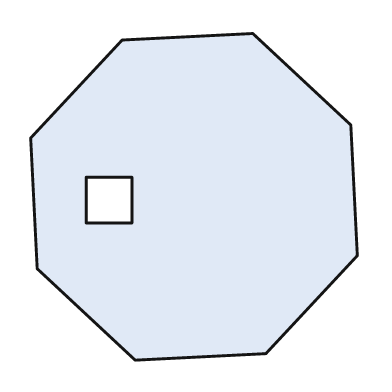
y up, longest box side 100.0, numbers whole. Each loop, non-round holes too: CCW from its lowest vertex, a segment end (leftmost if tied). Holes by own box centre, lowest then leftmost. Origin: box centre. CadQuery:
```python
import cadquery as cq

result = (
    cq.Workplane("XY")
    .moveTo(-18.0, -50.0)
    .lineTo(22.0, -48.0)
    .lineTo(50.0, -18.0)
    .lineTo(48.0, 22.0)
    .lineTo(18.0, 50.0)
    .lineTo(-22.0, 48.0)
    .lineTo(-50.0, 18.0)
    .lineTo(-48.0, -22.0)
    .close()
    .moveTo(-33.0, -8.0)
    .lineTo(-19.0, -8.0)
    .lineTo(-19.0, 6.0)
    .lineTo(-33.0, 6.0)
    .close()
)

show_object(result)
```